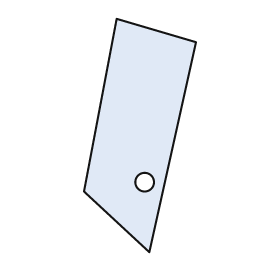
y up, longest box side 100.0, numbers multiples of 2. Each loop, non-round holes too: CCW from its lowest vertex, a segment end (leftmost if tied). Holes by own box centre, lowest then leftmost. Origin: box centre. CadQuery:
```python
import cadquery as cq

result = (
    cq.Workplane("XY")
    .moveTo(4.0, -50.0)
    .lineTo(24.0, 40.0)
    .lineTo(-10.0, 50.0)
    .lineTo(-24.0, -24.0)
    .close()
    .moveTo(2.0, -20.0)
    .circle(4.0)
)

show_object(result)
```